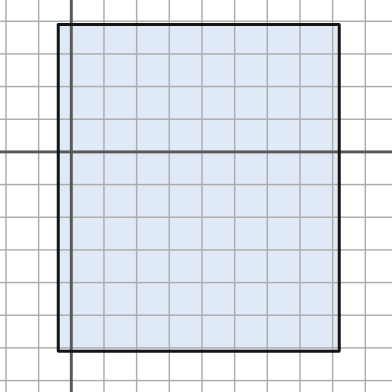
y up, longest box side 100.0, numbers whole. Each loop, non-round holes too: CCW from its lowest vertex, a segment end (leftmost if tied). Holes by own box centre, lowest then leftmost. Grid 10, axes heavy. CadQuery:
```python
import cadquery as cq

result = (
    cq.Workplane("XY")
    .moveTo(-4.0, -61.0)
    .lineTo(82.0, -61.0)
    .lineTo(82.0, 39.0)
    .lineTo(-4.0, 39.0)
    .close()
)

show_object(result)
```